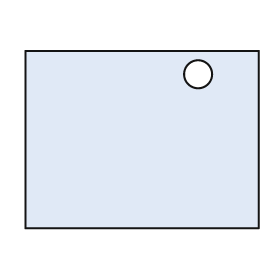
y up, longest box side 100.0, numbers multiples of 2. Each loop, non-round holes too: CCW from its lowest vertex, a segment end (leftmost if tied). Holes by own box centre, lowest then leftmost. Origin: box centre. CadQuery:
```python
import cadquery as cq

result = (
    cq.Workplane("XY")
    .moveTo(-50.0, -38.0)
    .lineTo(50.0, -38.0)
    .lineTo(50.0, 38.0)
    .lineTo(-50.0, 38.0)
    .close()
    .moveTo(24.0, 28.0)
    .circle(6.0)
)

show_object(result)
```